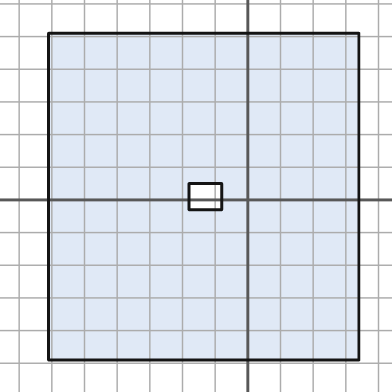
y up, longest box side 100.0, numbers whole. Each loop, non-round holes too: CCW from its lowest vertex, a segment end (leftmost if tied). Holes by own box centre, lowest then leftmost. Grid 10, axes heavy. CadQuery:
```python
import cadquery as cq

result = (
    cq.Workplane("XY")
    .moveTo(-61.0, -49.0)
    .lineTo(34.0, -49.0)
    .lineTo(34.0, 51.0)
    .lineTo(-61.0, 51.0)
    .close()
    .moveTo(-18.0, -3.0)
    .lineTo(-8.0, -3.0)
    .lineTo(-8.0, 5.0)
    .lineTo(-18.0, 5.0)
    .close()
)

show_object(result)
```